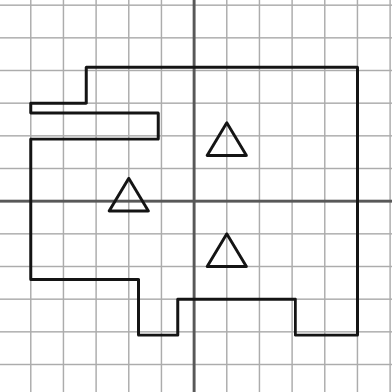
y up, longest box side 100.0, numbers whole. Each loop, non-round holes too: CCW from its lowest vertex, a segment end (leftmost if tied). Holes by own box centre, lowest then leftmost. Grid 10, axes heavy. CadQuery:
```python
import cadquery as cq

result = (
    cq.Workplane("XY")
    .moveTo(-17.0, -41.0)
    .lineTo(-5.0, -41.0)
    .lineTo(-5.0, -30.0)
    .lineTo(31.0, -30.0)
    .lineTo(31.0, -41.0)
    .lineTo(50.0, -41.0)
    .lineTo(50.0, 41.0)
    .lineTo(-33.0, 41.0)
    .lineTo(-33.0, 30.0)
    .lineTo(-50.0, 30.0)
    .lineTo(-50.0, 27.0)
    .lineTo(-11.0, 27.0)
    .lineTo(-11.0, 19.0)
    .lineTo(-50.0, 19.0)
    .lineTo(-50.0, -24.0)
    .lineTo(-17.0, -24.0)
    .close()
    .moveTo(4.0, -20.0)
    .lineTo(16.0, -20.0)
    .lineTo(10.0, -10.0)
    .close()
    .moveTo(-26.0, -3.0)
    .lineTo(-14.0, -3.0)
    .lineTo(-20.0, 7.0)
    .close()
    .moveTo(4.0, 14.0)
    .lineTo(16.0, 14.0)
    .lineTo(10.0, 24.0)
    .close()
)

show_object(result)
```